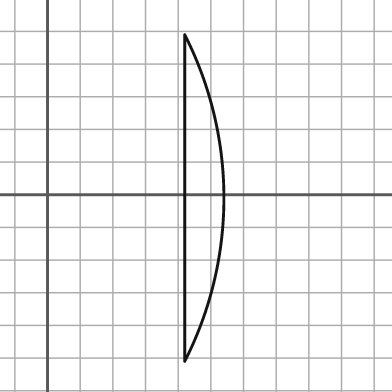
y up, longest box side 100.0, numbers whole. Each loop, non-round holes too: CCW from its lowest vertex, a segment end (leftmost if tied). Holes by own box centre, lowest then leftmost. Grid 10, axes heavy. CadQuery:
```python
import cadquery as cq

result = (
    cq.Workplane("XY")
    .moveTo(42.0, -51.0)
    .threePointArc((54.0, -1.0), (42.0, 49.0))
    .close()
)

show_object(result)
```